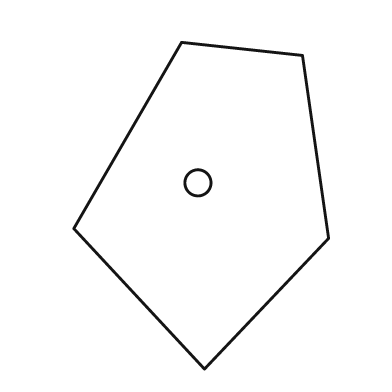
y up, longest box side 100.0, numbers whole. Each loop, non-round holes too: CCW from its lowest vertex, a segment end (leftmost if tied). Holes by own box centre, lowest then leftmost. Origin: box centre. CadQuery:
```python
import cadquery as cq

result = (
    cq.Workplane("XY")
    .moveTo(1.0, -50.0)
    .lineTo(39.0, -10.0)
    .lineTo(31.0, 46.0)
    .lineTo(-6.0, 50.0)
    .lineTo(-39.0, -7.0)
    .close()
    .moveTo(-1.0, 7.0)
    .circle(4.0)
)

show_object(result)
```